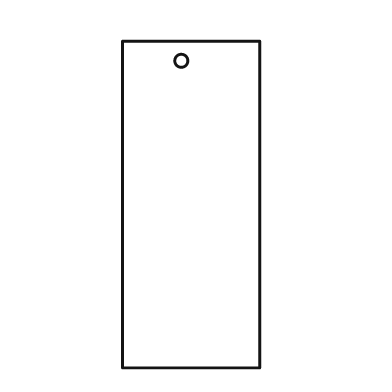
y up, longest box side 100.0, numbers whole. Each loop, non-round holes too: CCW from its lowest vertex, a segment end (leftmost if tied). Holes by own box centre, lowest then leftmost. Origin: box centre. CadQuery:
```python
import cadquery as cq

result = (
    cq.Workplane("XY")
    .moveTo(-21.0, -50.0)
    .lineTo(21.0, -50.0)
    .lineTo(21.0, 50.0)
    .lineTo(-21.0, 50.0)
    .close()
    .moveTo(-3.0, 44.0)
    .circle(2.0)
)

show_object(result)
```